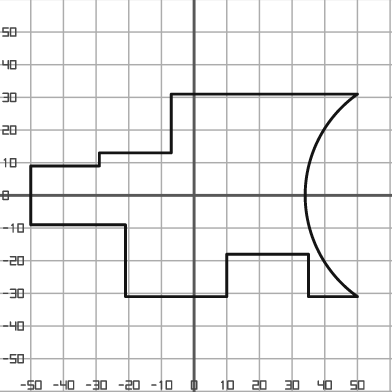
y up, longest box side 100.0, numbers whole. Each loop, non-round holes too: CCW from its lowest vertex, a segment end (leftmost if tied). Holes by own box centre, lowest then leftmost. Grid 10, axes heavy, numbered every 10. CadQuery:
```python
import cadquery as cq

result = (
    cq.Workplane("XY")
    .moveTo(-21.0, -31.0)
    .lineTo(10.0, -31.0)
    .lineTo(10.0, -18.0)
    .lineTo(35.0, -18.0)
    .lineTo(35.0, -31.0)
    .lineTo(50.0, -31.0)
    .threePointArc((34.0, 0.0), (50.0, 31.0))
    .lineTo(-7.0, 31.0)
    .lineTo(-7.0, 13.0)
    .lineTo(-29.0, 13.0)
    .lineTo(-29.0, 9.0)
    .lineTo(-50.0, 9.0)
    .lineTo(-50.0, -9.0)
    .lineTo(-21.0, -9.0)
    .close()
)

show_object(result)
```